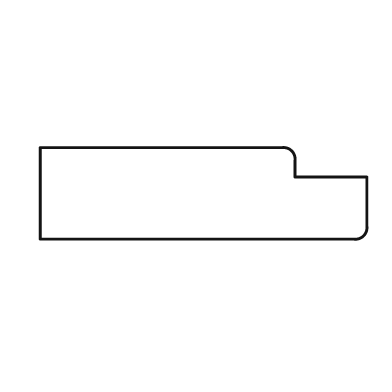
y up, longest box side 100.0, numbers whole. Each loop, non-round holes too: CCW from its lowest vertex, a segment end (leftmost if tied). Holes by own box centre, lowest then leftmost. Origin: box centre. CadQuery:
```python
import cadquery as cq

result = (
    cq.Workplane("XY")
    .moveTo(-50.0, -14.0)
    .lineTo(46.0, -14.0)
    .threePointArc((49.0, -13.0), (50.0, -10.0))
    .lineTo(50.0, 5.0)
    .lineTo(28.0, 5.0)
    .lineTo(28.0, 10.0)
    .threePointArc((27.0, 13.0), (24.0, 14.0))
    .lineTo(-50.0, 14.0)
    .close()
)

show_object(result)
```